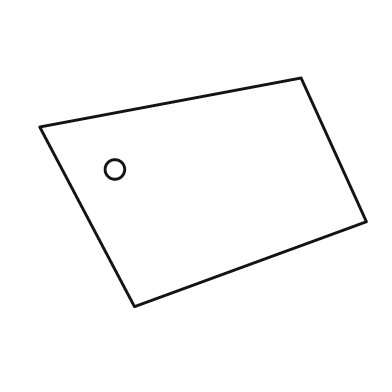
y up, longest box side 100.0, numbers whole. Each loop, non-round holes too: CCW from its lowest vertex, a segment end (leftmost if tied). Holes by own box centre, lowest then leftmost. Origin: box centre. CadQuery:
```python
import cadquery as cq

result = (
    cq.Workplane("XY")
    .moveTo(-21.0, -35.0)
    .lineTo(50.0, -9.0)
    .lineTo(30.0, 35.0)
    .lineTo(-50.0, 20.0)
    .close()
    .moveTo(-27.0, 7.0)
    .circle(3.0)
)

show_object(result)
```